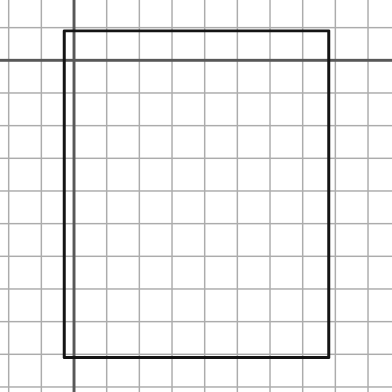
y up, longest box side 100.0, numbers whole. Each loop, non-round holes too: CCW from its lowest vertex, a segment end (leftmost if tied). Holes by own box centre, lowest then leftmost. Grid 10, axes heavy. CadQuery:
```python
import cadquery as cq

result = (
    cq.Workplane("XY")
    .moveTo(-3.0, -91.0)
    .lineTo(78.0, -91.0)
    .lineTo(78.0, 9.0)
    .lineTo(-3.0, 9.0)
    .close()
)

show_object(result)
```